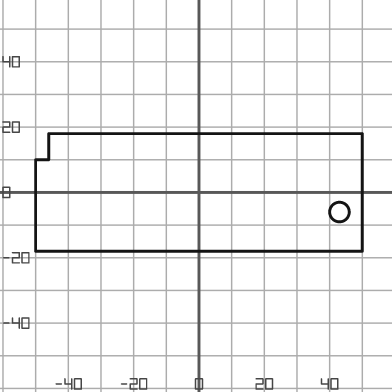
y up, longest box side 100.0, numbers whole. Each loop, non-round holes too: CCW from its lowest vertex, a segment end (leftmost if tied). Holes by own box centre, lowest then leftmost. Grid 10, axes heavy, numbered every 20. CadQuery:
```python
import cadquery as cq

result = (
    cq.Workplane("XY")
    .moveTo(-50.0, -18.0)
    .lineTo(50.0, -18.0)
    .lineTo(50.0, 18.0)
    .lineTo(-46.0, 18.0)
    .lineTo(-46.0, 10.0)
    .lineTo(-50.0, 10.0)
    .close()
    .moveTo(43.0, -6.0)
    .circle(3.0)
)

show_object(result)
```